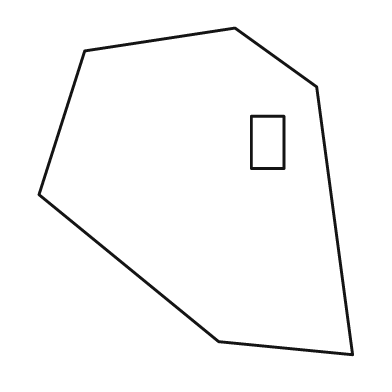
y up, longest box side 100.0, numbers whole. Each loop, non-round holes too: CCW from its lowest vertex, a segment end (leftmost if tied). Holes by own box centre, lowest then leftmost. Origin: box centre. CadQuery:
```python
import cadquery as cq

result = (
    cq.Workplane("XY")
    .moveTo(48.0, -50.0)
    .lineTo(37.0, 32.0)
    .lineTo(12.0, 50.0)
    .lineTo(-34.0, 43.0)
    .lineTo(-48.0, -1.0)
    .lineTo(7.0, -46.0)
    .close()
    .moveTo(17.0, 7.0)
    .lineTo(27.0, 7.0)
    .lineTo(27.0, 23.0)
    .lineTo(17.0, 23.0)
    .close()
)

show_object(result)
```